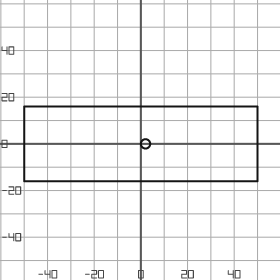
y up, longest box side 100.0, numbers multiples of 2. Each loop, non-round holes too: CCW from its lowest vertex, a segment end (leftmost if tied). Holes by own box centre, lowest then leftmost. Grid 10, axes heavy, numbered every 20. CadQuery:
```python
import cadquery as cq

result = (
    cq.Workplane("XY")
    .moveTo(-50.0, -16.0)
    .lineTo(50.0, -16.0)
    .lineTo(50.0, 16.0)
    .lineTo(-50.0, 16.0)
    .close()
    .moveTo(2.0, 0.0)
    .circle(2.0)
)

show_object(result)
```